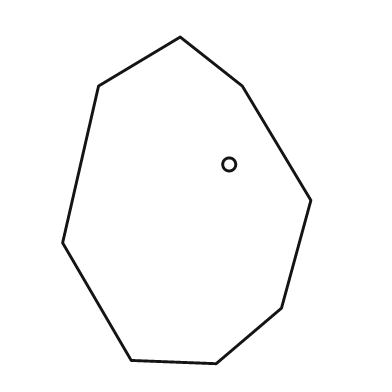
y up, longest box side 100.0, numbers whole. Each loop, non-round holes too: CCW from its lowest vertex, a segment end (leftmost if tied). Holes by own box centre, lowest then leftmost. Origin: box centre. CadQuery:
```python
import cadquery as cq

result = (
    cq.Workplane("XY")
    .moveTo(9.0, -50.0)
    .lineTo(29.0, -33.0)
    .lineTo(38.0, 0.0)
    .lineTo(17.0, 35.0)
    .lineTo(-2.0, 50.0)
    .lineTo(-27.0, 35.0)
    .lineTo(-38.0, -13.0)
    .lineTo(-17.0, -49.0)
    .close()
    .moveTo(13.0, 11.0)
    .circle(2.0)
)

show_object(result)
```